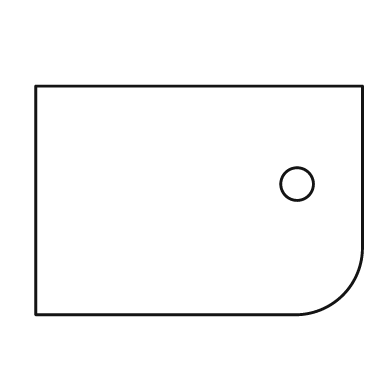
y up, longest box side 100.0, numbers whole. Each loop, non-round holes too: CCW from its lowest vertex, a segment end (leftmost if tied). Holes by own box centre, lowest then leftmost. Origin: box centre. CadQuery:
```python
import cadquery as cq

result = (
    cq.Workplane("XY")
    .moveTo(-50.0, -35.0)
    .lineTo(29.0, -35.0)
    .threePointArc((44.0, -29.0), (50.0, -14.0))
    .lineTo(50.0, 35.0)
    .lineTo(-50.0, 35.0)
    .close()
    .moveTo(30.0, 5.0)
    .circle(5.0)
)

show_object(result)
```